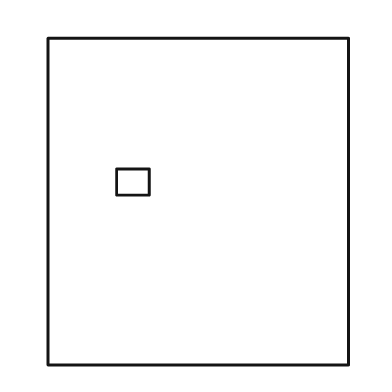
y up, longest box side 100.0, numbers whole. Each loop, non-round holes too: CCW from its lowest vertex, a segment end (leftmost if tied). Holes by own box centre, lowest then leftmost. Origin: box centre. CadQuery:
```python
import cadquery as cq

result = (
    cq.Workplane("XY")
    .moveTo(-46.0, -50.0)
    .lineTo(46.0, -50.0)
    .lineTo(46.0, 50.0)
    .lineTo(-46.0, 50.0)
    .close()
    .moveTo(-25.0, 2.0)
    .lineTo(-15.0, 2.0)
    .lineTo(-15.0, 10.0)
    .lineTo(-25.0, 10.0)
    .close()
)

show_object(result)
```